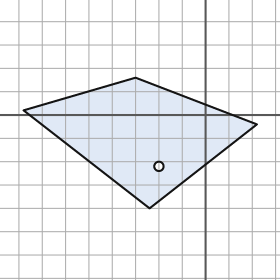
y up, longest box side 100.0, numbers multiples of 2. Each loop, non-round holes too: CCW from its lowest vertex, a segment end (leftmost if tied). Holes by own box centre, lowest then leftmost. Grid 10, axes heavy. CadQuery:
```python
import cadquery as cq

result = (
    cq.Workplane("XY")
    .moveTo(-24.0, -40.0)
    .lineTo(22.0, -4.0)
    .lineTo(-30.0, 16.0)
    .lineTo(-78.0, 2.0)
    .close()
    .moveTo(-20.0, -22.0)
    .circle(2.0)
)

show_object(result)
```